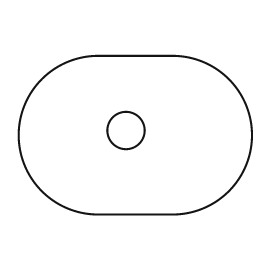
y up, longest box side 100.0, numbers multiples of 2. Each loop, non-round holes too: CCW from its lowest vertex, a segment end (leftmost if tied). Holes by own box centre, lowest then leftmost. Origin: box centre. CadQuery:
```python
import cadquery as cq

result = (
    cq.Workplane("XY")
    .moveTo(-16.0, -34.0)
    .lineTo(16.0, -34.0)
    .threePointArc((50.0, 0.0), (16.0, 34.0))
    .lineTo(-16.0, 34.0)
    .threePointArc((-50.0, 0.0), (-16.0, -34.0))
    .close()
    .moveTo(-4.0, 2.0)
    .circle(8.0)
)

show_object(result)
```